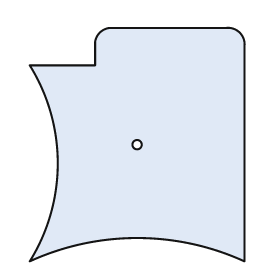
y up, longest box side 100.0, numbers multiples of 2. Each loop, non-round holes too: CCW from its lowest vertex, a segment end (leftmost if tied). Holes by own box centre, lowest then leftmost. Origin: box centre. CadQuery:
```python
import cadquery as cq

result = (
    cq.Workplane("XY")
    .moveTo(-46.0, -50.0)
    .threePointArc((0.0, -40.0), (46.0, -50.0))
    .lineTo(46.0, 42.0)
    .threePointArc((44.0, 48.0), (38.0, 50.0))
    .lineTo(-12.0, 50.0)
    .threePointArc((-16.0, 48.0), (-18.0, 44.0))
    .lineTo(-18.0, 34.0)
    .lineTo(-46.0, 34.0)
    .threePointArc((-34.0, -8.0), (-46.0, -50.0))
    .close()
    .moveTo(0.0, 0.0)
    .circle(2.0)
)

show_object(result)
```